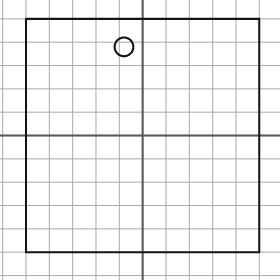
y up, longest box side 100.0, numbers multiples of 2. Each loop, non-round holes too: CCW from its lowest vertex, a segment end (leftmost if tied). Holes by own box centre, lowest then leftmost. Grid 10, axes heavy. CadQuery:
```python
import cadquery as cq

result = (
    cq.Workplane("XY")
    .moveTo(-50.0, -50.0)
    .lineTo(50.0, -50.0)
    .lineTo(50.0, 50.0)
    .lineTo(-50.0, 50.0)
    .close()
    .moveTo(-8.0, 38.0)
    .circle(4.0)
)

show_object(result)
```